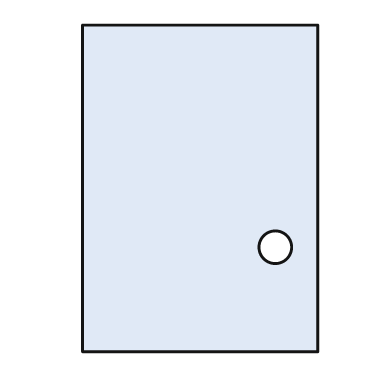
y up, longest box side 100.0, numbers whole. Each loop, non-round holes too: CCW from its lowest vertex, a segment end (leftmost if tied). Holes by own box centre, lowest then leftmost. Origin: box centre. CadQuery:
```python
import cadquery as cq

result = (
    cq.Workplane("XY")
    .moveTo(-36.0, -50.0)
    .lineTo(36.0, -50.0)
    .lineTo(36.0, 50.0)
    .lineTo(-36.0, 50.0)
    .close()
    .moveTo(23.0, -18.0)
    .circle(5.0)
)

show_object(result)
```